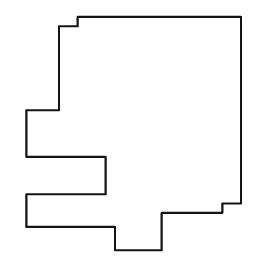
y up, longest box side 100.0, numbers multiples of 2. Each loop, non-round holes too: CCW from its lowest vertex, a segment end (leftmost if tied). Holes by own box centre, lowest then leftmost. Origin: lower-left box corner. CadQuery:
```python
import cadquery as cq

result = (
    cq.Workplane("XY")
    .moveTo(38.0, 0.0)
    .lineTo(58.0, 0.0)
    .lineTo(58.0, 16.0)
    .lineTo(84.0, 16.0)
    .lineTo(84.0, 20.0)
    .lineTo(92.0, 20.0)
    .lineTo(92.0, 100.0)
    .lineTo(22.0, 100.0)
    .lineTo(22.0, 96.0)
    .lineTo(14.0, 96.0)
    .lineTo(14.0, 60.0)
    .lineTo(0.0, 60.0)
    .lineTo(0.0, 40.0)
    .lineTo(34.0, 40.0)
    .lineTo(34.0, 24.0)
    .lineTo(0.0, 24.0)
    .lineTo(0.0, 10.0)
    .lineTo(38.0, 10.0)
    .close()
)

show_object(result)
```